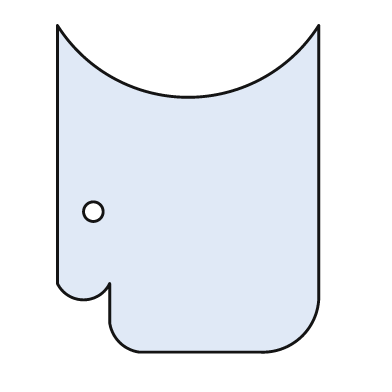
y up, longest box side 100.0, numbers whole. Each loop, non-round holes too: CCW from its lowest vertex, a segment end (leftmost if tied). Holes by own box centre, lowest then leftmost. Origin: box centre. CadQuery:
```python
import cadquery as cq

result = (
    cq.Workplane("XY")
    .moveTo(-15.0, -50.0)
    .lineTo(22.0, -50.0)
    .threePointArc((35.0, -45.0), (40.0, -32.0))
    .lineTo(40.0, 50.0)
    .threePointArc((0.0, 28.0), (-40.0, 50.0))
    .lineTo(-40.0, -29.0)
    .threePointArc((-32.0, -34.0), (-24.0, -29.0))
    .lineTo(-24.0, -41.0)
    .threePointArc((-21.0, -47.0), (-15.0, -50.0))
    .close()
    .moveTo(-29.0, -7.0)
    .circle(3.0)
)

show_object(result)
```